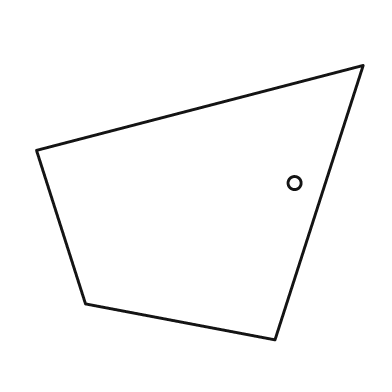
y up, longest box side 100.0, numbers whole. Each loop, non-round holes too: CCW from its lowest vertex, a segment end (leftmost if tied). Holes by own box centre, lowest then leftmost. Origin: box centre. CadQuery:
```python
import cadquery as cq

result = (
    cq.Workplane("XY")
    .moveTo(23.0, -42.0)
    .lineTo(50.0, 42.0)
    .lineTo(-50.0, 16.0)
    .lineTo(-35.0, -31.0)
    .close()
    .moveTo(29.0, 6.0)
    .circle(2.0)
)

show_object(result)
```